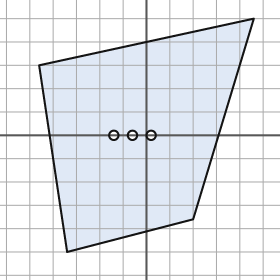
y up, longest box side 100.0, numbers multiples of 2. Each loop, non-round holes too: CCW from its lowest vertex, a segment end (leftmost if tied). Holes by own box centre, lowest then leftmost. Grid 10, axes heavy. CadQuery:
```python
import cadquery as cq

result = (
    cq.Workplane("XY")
    .moveTo(-34.0, -50.0)
    .lineTo(20.0, -36.0)
    .lineTo(46.0, 50.0)
    .lineTo(-46.0, 30.0)
    .close()
    .moveTo(-14.0, 0.0)
    .circle(2.0)
    .moveTo(-6.0, 0.0)
    .circle(2.0)
    .moveTo(2.0, 0.0)
    .circle(2.0)
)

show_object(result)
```